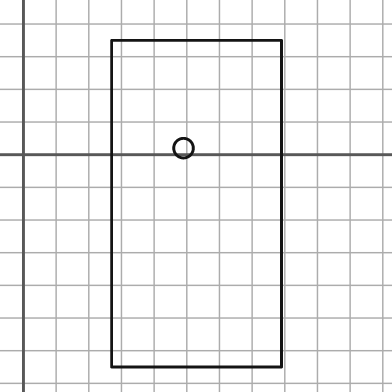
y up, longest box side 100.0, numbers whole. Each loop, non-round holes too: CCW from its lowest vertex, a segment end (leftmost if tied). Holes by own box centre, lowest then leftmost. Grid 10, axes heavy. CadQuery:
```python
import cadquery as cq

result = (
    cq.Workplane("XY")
    .moveTo(27.0, -65.0)
    .lineTo(79.0, -65.0)
    .lineTo(79.0, 35.0)
    .lineTo(27.0, 35.0)
    .close()
    .moveTo(49.0, 2.0)
    .circle(3.0)
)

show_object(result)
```